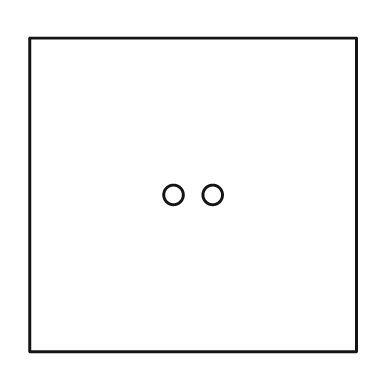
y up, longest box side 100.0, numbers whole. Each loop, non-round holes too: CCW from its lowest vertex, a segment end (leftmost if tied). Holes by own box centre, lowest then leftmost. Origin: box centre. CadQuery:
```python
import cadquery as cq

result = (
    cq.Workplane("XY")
    .moveTo(-50.0, -48.0)
    .lineTo(50.0, -48.0)
    .lineTo(50.0, 48.0)
    .lineTo(-50.0, 48.0)
    .close()
    .moveTo(-6.0, 0.0)
    .circle(3.0)
    .moveTo(6.0, 0.0)
    .circle(3.0)
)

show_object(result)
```